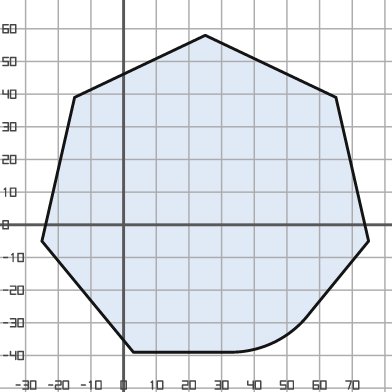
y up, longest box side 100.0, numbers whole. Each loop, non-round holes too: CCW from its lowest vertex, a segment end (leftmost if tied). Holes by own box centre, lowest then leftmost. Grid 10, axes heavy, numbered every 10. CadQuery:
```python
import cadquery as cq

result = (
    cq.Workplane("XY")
    .moveTo(3.0, -39.0)
    .lineTo(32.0, -39.0)
    .threePointArc((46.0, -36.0), (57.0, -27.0))
    .lineTo(75.0, -5.0)
    .lineTo(65.0, 39.0)
    .lineTo(25.0, 58.0)
    .lineTo(-15.0, 39.0)
    .lineTo(-25.0, -5.0)
    .close()
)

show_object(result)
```